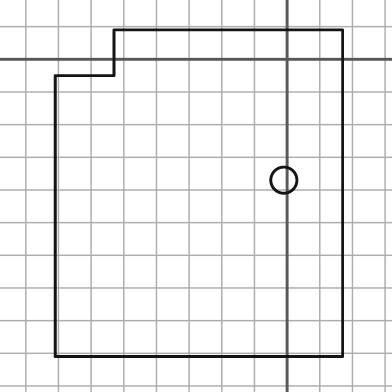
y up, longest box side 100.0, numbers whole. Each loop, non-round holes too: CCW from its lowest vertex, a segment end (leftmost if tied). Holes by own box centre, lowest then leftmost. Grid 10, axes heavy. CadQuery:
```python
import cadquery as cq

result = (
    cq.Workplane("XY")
    .moveTo(-71.0, -91.0)
    .lineTo(17.0, -91.0)
    .lineTo(17.0, 9.0)
    .lineTo(-53.0, 9.0)
    .lineTo(-53.0, -5.0)
    .lineTo(-71.0, -5.0)
    .close()
    .moveTo(-1.0, -37.0)
    .circle(4.0)
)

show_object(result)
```